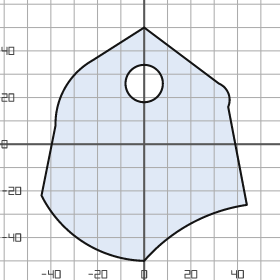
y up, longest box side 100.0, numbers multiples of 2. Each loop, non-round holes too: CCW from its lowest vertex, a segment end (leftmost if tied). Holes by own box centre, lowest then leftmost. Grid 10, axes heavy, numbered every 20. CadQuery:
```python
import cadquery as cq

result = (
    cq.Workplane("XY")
    .moveTo(0.0, -50.0)
    .threePointArc((20.0, -34.0), (44.0, -26.0))
    .lineTo(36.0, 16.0)
    .threePointArc((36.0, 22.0), (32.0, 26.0))
    .lineTo(0.0, 50.0)
    .lineTo(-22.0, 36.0)
    .threePointArc((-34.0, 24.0), (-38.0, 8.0))
    .lineTo(-44.0, -22.0)
    .threePointArc((-26.0, -42.0), (0.0, -50.0))
    .close()
    .moveTo(0.0, 26.0)
    .circle(8.0)
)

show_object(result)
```